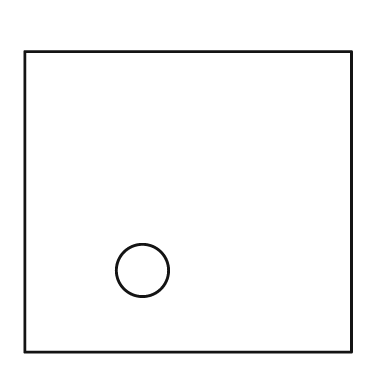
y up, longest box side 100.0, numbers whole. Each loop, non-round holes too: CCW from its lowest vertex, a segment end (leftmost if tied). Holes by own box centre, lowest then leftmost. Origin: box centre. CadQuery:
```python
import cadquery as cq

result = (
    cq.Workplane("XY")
    .moveTo(-50.0, -46.0)
    .lineTo(50.0, -46.0)
    .lineTo(50.0, 46.0)
    .lineTo(-50.0, 46.0)
    .close()
    .moveTo(-14.0, -21.0)
    .circle(8.0)
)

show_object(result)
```